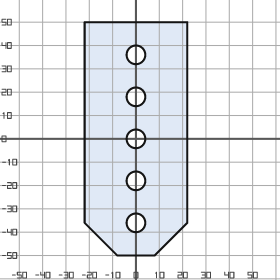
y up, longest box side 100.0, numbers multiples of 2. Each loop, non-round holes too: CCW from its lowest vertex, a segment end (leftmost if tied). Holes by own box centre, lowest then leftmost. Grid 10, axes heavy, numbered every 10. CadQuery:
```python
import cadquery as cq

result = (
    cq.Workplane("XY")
    .moveTo(-8.0, -50.0)
    .lineTo(8.0, -50.0)
    .lineTo(22.0, -36.0)
    .lineTo(22.0, 50.0)
    .lineTo(-22.0, 50.0)
    .lineTo(-22.0, -36.0)
    .close()
    .moveTo(0.0, -36.0)
    .circle(4.0)
    .moveTo(0.0, -18.0)
    .circle(4.0)
    .moveTo(0.0, 0.0)
    .circle(4.0)
    .moveTo(0.0, 18.0)
    .circle(4.0)
    .moveTo(0.0, 36.0)
    .circle(4.0)
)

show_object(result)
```